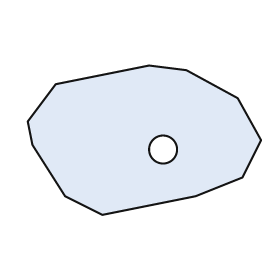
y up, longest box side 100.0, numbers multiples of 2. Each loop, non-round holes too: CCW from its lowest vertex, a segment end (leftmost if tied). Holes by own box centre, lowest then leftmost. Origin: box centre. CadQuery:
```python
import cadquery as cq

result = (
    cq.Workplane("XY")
    .moveTo(-18.0, -32.0)
    .lineTo(22.0, -24.0)
    .lineTo(42.0, -16.0)
    .lineTo(50.0, 0.0)
    .lineTo(40.0, 18.0)
    .lineTo(18.0, 30.0)
    .lineTo(2.0, 32.0)
    .lineTo(-38.0, 24.0)
    .lineTo(-50.0, 8.0)
    .lineTo(-48.0, -2.0)
    .lineTo(-34.0, -24.0)
    .close()
    .moveTo(8.0, -4.0)
    .circle(6.0)
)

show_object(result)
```